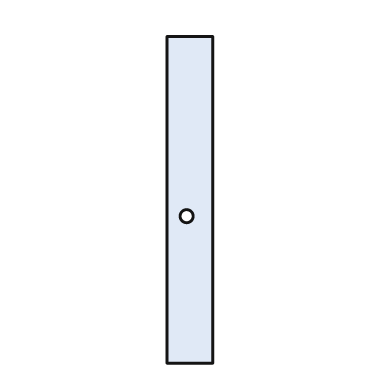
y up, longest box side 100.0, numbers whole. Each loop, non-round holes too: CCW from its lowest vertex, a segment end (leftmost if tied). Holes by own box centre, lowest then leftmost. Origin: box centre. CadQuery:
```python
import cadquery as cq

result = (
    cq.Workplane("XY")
    .moveTo(-7.0, -50.0)
    .lineTo(7.0, -50.0)
    .lineTo(7.0, 50.0)
    .lineTo(-7.0, 50.0)
    .close()
    .moveTo(-1.0, -5.0)
    .circle(2.0)
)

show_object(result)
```